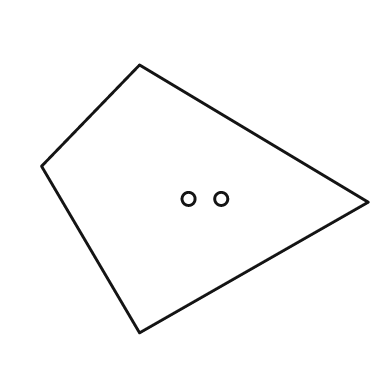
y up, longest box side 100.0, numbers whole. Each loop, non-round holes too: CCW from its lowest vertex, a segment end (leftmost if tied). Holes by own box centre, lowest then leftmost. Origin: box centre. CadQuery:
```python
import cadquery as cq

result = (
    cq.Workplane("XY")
    .moveTo(-20.0, -41.0)
    .lineTo(50.0, -1.0)
    .lineTo(-20.0, 41.0)
    .lineTo(-50.0, 10.0)
    .close()
    .moveTo(-5.0, 0.0)
    .circle(2.0)
    .moveTo(5.0, 0.0)
    .circle(2.0)
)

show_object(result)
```